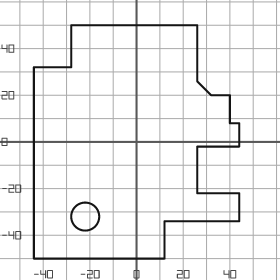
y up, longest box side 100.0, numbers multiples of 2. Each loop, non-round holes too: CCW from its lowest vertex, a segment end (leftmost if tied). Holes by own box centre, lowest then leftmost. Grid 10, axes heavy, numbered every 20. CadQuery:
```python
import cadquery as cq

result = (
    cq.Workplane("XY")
    .moveTo(-44.0, -50.0)
    .lineTo(12.0, -50.0)
    .lineTo(12.0, -34.0)
    .lineTo(44.0, -34.0)
    .lineTo(44.0, -22.0)
    .lineTo(26.0, -22.0)
    .lineTo(26.0, -2.0)
    .lineTo(44.0, -2.0)
    .lineTo(44.0, 8.0)
    .lineTo(40.0, 8.0)
    .lineTo(40.0, 20.0)
    .lineTo(32.0, 20.0)
    .lineTo(26.0, 26.0)
    .lineTo(26.0, 50.0)
    .lineTo(-28.0, 50.0)
    .lineTo(-28.0, 32.0)
    .lineTo(-44.0, 32.0)
    .close()
    .moveTo(-22.0, -32.0)
    .circle(6.0)
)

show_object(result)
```